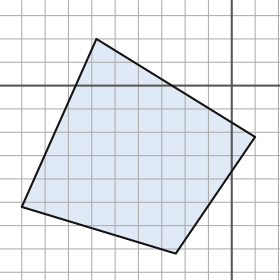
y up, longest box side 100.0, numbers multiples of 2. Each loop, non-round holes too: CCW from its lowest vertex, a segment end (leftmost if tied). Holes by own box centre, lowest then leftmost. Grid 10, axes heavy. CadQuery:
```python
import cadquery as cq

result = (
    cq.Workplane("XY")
    .moveTo(-24.0, -72.0)
    .lineTo(10.0, -22.0)
    .lineTo(-58.0, 20.0)
    .lineTo(-90.0, -52.0)
    .close()
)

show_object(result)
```